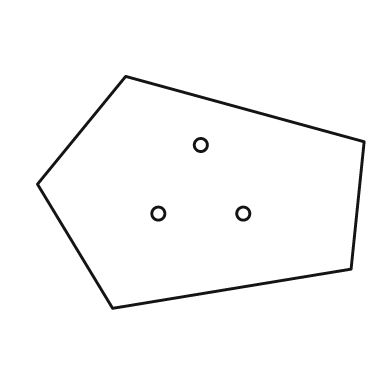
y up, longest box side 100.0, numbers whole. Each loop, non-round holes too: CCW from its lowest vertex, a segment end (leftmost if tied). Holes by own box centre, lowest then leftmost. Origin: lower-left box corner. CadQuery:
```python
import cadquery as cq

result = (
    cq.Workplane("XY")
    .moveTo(23.0, 0.0)
    .lineTo(96.0, 12.0)
    .lineTo(100.0, 51.0)
    .lineTo(27.0, 71.0)
    .lineTo(0.0, 38.0)
    .close()
    .moveTo(37.0, 29.0)
    .circle(2.0)
    .moveTo(63.0, 29.0)
    .circle(2.0)
    .moveTo(50.0, 50.0)
    .circle(2.0)
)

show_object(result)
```